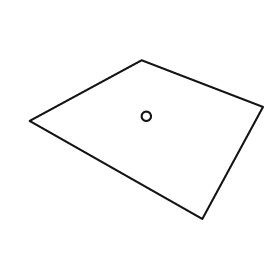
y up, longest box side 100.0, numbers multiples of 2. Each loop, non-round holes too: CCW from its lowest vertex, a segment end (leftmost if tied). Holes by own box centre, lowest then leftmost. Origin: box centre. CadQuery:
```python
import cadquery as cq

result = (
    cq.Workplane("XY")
    .moveTo(24.0, -34.0)
    .lineTo(50.0, 14.0)
    .lineTo(-2.0, 34.0)
    .lineTo(-50.0, 8.0)
    .close()
    .moveTo(0.0, 10.0)
    .circle(2.0)
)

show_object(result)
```